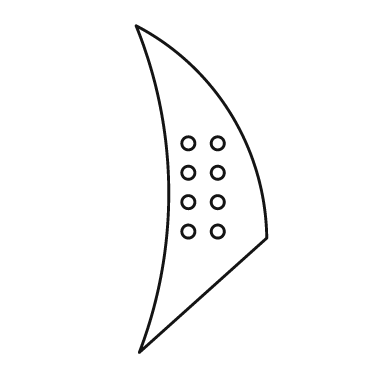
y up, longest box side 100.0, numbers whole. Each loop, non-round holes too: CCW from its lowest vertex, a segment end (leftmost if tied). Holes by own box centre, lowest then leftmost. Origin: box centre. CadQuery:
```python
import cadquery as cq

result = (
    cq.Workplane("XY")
    .moveTo(-19.0, -50.0)
    .lineTo(20.0, -15.0)
    .threePointArc((9.0, 23.0), (-20.0, 50.0))
    .threePointArc((-10.0, 0.0), (-19.0, -50.0))
    .close()
    .moveTo(-4.0, -13.0)
    .circle(2.0)
    .moveTo(5.0, -13.0)
    .circle(2.0)
    .moveTo(-4.0, -4.0)
    .circle(2.0)
    .moveTo(5.0, -4.0)
    .circle(2.0)
    .moveTo(-4.0, 5.0)
    .circle(2.0)
    .moveTo(5.0, 5.0)
    .circle(2.0)
    .moveTo(-4.0, 14.0)
    .circle(2.0)
    .moveTo(5.0, 14.0)
    .circle(2.0)
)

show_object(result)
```